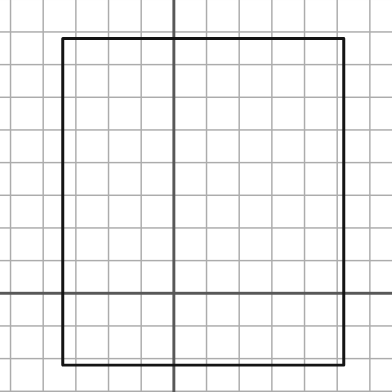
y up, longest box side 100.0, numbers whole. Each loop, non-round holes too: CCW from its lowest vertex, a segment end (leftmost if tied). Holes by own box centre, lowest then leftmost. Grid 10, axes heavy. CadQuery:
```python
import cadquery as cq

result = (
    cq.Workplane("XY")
    .moveTo(-34.0, -22.0)
    .lineTo(52.0, -22.0)
    .lineTo(52.0, 78.0)
    .lineTo(-34.0, 78.0)
    .close()
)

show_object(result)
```